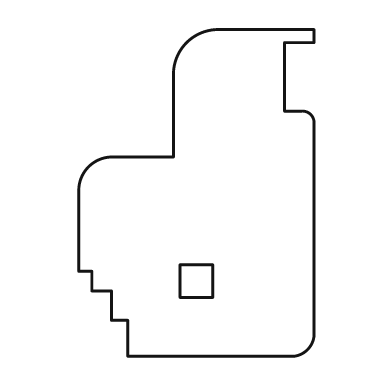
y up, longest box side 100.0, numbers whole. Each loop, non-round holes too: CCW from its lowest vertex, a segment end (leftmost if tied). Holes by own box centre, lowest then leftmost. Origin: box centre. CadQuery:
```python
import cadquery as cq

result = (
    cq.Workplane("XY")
    .moveTo(-21.0, -50.0)
    .lineTo(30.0, -50.0)
    .threePointArc((34.0, -48.0), (36.0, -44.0))
    .lineTo(36.0, 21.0)
    .threePointArc((35.0, 24.0), (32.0, 25.0))
    .lineTo(27.0, 25.0)
    .lineTo(27.0, 46.0)
    .lineTo(36.0, 46.0)
    .lineTo(36.0, 50.0)
    .lineTo(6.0, 50.0)
    .threePointArc((-3.0, 46.0), (-7.0, 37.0))
    .lineTo(-7.0, 11.0)
    .lineTo(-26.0, 11.0)
    .threePointArc((-33.0, 8.0), (-36.0, 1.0))
    .lineTo(-36.0, -24.0)
    .lineTo(-32.0, -24.0)
    .lineTo(-32.0, -30.0)
    .lineTo(-26.0, -30.0)
    .lineTo(-26.0, -39.0)
    .lineTo(-21.0, -39.0)
    .close()
    .moveTo(-5.0, -32.0)
    .lineTo(5.0, -32.0)
    .lineTo(5.0, -22.0)
    .lineTo(-5.0, -22.0)
    .close()
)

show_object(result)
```